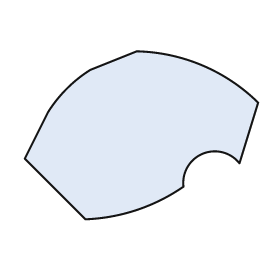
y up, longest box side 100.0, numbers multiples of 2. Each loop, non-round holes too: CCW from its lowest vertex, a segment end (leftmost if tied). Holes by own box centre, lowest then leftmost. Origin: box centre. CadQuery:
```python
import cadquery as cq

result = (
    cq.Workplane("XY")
    .moveTo(-24.0, -36.0)
    .threePointArc((-2.0, -32.0), (18.0, -22.0))
    .threePointArc((26.0, -8.0), (42.0, -12.0))
    .lineTo(50.0, 14.0)
    .threePointArc((26.0, 30.0), (-2.0, 36.0))
    .lineTo(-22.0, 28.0)
    .threePointArc((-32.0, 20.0), (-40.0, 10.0))
    .lineTo(-50.0, -10.0)
    .close()
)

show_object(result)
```